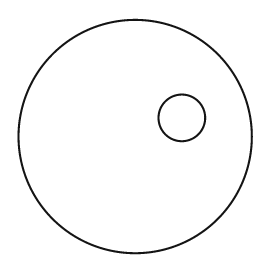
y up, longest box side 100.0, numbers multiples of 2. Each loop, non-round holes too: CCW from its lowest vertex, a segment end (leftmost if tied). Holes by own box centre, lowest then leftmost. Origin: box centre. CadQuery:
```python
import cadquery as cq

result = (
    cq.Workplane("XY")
    .moveTo(0.0, 0.0)
    .circle(50.0)
    .moveTo(20.0, 8.0)
    .circle(10.0)
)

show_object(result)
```